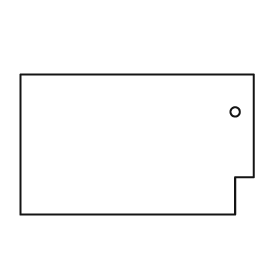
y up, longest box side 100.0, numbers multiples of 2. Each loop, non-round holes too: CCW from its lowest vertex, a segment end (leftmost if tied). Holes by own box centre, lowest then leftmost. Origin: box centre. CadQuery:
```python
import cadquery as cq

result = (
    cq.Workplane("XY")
    .moveTo(-50.0, -30.0)
    .lineTo(42.0, -30.0)
    .lineTo(42.0, -14.0)
    .lineTo(50.0, -14.0)
    .lineTo(50.0, 30.0)
    .lineTo(-50.0, 30.0)
    .close()
    .moveTo(42.0, 14.0)
    .circle(2.0)
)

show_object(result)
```